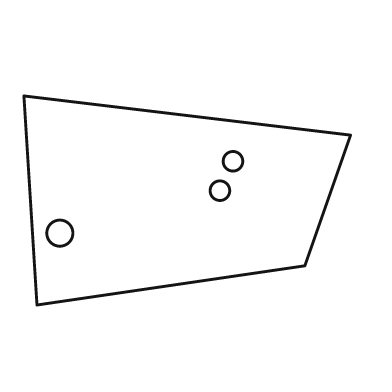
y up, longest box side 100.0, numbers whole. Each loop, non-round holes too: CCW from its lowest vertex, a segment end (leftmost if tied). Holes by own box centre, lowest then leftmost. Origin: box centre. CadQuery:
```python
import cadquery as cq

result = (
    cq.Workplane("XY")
    .moveTo(-46.0, -32.0)
    .lineTo(36.0, -20.0)
    .lineTo(50.0, 20.0)
    .lineTo(-50.0, 32.0)
    .close()
    .moveTo(-39.0, -10.0)
    .circle(4.0)
    .moveTo(10.0, 3.0)
    .circle(3.0)
    .moveTo(14.0, 12.0)
    .circle(3.0)
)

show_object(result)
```